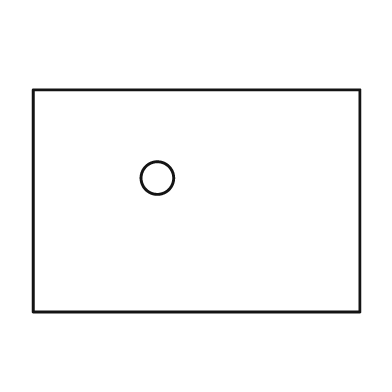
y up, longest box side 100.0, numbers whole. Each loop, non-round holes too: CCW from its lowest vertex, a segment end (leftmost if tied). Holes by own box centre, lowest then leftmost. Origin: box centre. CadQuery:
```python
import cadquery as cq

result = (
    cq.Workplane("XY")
    .moveTo(-50.0, -34.0)
    .lineTo(50.0, -34.0)
    .lineTo(50.0, 34.0)
    .lineTo(-50.0, 34.0)
    .close()
    .moveTo(-12.0, 7.0)
    .circle(5.0)
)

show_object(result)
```